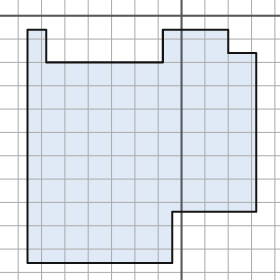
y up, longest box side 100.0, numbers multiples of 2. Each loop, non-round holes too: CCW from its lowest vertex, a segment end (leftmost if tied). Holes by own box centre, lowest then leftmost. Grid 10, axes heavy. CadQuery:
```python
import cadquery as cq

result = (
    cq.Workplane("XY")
    .moveTo(-66.0, -106.0)
    .lineTo(-4.0, -106.0)
    .lineTo(-4.0, -84.0)
    .lineTo(32.0, -84.0)
    .lineTo(32.0, -16.0)
    .lineTo(20.0, -16.0)
    .lineTo(20.0, -6.0)
    .lineTo(-8.0, -6.0)
    .lineTo(-8.0, -20.0)
    .lineTo(-58.0, -20.0)
    .lineTo(-58.0, -6.0)
    .lineTo(-66.0, -6.0)
    .close()
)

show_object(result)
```